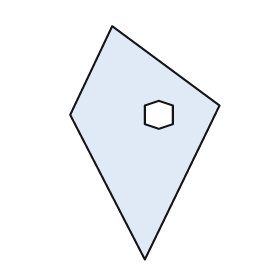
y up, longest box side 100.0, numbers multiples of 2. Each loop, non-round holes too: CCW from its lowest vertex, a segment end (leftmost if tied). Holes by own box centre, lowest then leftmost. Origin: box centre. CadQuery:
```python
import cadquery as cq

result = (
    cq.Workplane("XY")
    .moveTo(0.0, -50.0)
    .lineTo(32.0, 16.0)
    .lineTo(-14.0, 50.0)
    .lineTo(-32.0, 12.0)
    .close()
    .moveTo(6.0, 6.0)
    .lineTo(12.0, 8.0)
    .lineTo(12.0, 16.0)
    .lineTo(6.0, 18.0)
    .lineTo(0.0, 16.0)
    .lineTo(0.0, 8.0)
    .close()
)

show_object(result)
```